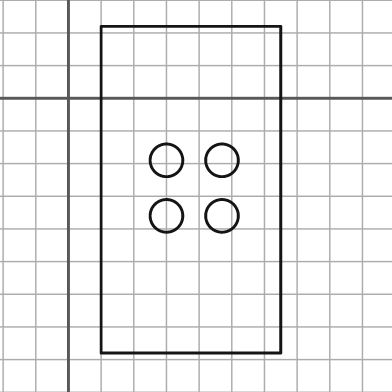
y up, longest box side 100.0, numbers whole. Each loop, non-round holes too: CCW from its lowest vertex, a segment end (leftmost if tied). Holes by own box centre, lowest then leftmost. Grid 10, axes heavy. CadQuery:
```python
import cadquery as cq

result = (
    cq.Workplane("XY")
    .moveTo(10.0, -78.0)
    .lineTo(65.0, -78.0)
    .lineTo(65.0, 22.0)
    .lineTo(10.0, 22.0)
    .close()
    .moveTo(30.0, -36.0)
    .circle(5.0)
    .moveTo(47.0, -36.0)
    .circle(5.0)
    .moveTo(30.0, -19.0)
    .circle(5.0)
    .moveTo(47.0, -19.0)
    .circle(5.0)
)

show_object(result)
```